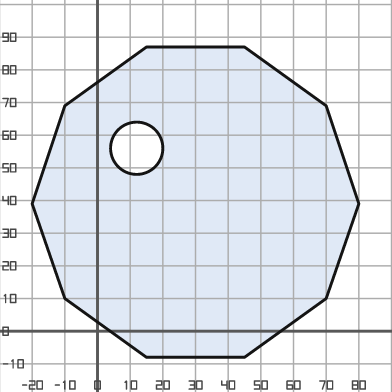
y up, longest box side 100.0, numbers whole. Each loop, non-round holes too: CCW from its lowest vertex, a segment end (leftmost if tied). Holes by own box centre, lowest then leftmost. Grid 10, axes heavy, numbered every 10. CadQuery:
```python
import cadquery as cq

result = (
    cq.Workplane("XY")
    .moveTo(15.0, -8.0)
    .lineTo(45.0, -8.0)
    .lineTo(70.0, 10.0)
    .lineTo(80.0, 39.0)
    .lineTo(70.0, 69.0)
    .lineTo(45.0, 87.0)
    .lineTo(15.0, 87.0)
    .lineTo(-10.0, 69.0)
    .lineTo(-20.0, 39.0)
    .lineTo(-10.0, 10.0)
    .close()
    .moveTo(12.0, 56.0)
    .circle(8.0)
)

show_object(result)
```